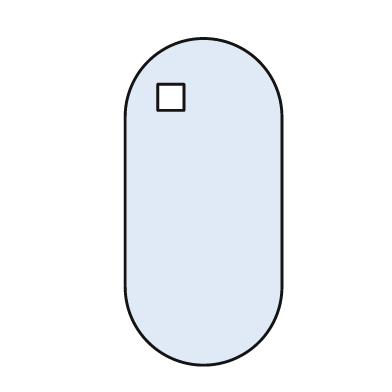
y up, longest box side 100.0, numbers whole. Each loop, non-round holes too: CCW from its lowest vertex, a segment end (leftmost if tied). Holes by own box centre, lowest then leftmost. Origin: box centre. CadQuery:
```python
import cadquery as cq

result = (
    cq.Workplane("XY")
    .moveTo(-24.0, -26.0)
    .threePointArc((0.0, -50.0), (24.0, -26.0))
    .lineTo(24.0, 26.0)
    .threePointArc((0.0, 50.0), (-24.0, 26.0))
    .close()
    .moveTo(-14.0, 28.0)
    .lineTo(-6.0, 28.0)
    .lineTo(-6.0, 36.0)
    .lineTo(-14.0, 36.0)
    .close()
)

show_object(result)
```